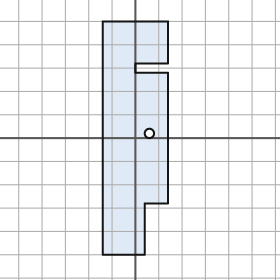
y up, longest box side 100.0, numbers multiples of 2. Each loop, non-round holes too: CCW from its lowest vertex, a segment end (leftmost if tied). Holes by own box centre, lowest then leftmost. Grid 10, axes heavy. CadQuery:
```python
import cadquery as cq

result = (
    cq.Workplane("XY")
    .moveTo(-14.0, -50.0)
    .lineTo(4.0, -50.0)
    .lineTo(4.0, -28.0)
    .lineTo(14.0, -28.0)
    .lineTo(14.0, 28.0)
    .lineTo(0.0, 28.0)
    .lineTo(0.0, 32.0)
    .lineTo(14.0, 32.0)
    .lineTo(14.0, 50.0)
    .lineTo(-14.0, 50.0)
    .close()
    .moveTo(6.0, 2.0)
    .circle(2.0)
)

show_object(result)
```